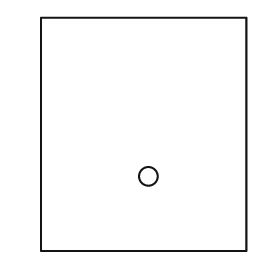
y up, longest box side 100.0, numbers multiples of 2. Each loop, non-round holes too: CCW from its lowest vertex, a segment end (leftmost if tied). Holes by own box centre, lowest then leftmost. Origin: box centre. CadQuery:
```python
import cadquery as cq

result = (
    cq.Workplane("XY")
    .moveTo(-44.0, -50.0)
    .lineTo(44.0, -50.0)
    .lineTo(44.0, 50.0)
    .lineTo(-44.0, 50.0)
    .close()
    .moveTo(2.0, -18.0)
    .circle(4.0)
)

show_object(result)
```